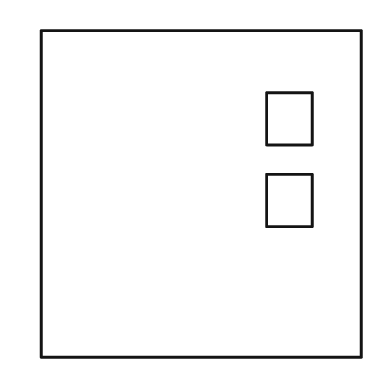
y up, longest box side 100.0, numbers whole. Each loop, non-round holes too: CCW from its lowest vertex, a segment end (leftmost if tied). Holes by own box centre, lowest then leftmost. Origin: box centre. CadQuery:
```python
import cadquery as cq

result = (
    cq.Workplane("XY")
    .moveTo(-49.0, -50.0)
    .lineTo(49.0, -50.0)
    .lineTo(49.0, 50.0)
    .lineTo(-49.0, 50.0)
    .close()
    .moveTo(20.0, -10.0)
    .lineTo(34.0, -10.0)
    .lineTo(34.0, 6.0)
    .lineTo(20.0, 6.0)
    .close()
    .moveTo(20.0, 15.0)
    .lineTo(34.0, 15.0)
    .lineTo(34.0, 31.0)
    .lineTo(20.0, 31.0)
    .close()
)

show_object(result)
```